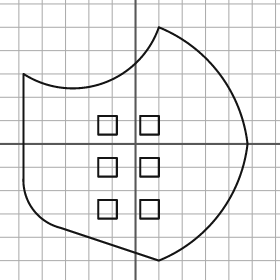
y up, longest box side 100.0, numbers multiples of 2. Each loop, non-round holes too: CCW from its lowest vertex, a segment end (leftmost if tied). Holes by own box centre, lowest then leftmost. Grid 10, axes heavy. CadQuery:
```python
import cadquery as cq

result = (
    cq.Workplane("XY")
    .moveTo(10.0, -50.0)
    .threePointArc((36.0, -30.0), (48.0, 0.0))
    .threePointArc((36.0, 30.0), (10.0, 50.0))
    .threePointArc((-14.0, 26.0), (-48.0, 30.0))
    .lineTo(-48.0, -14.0)
    .threePointArc((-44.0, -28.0), (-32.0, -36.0))
    .close()
    .moveTo(-16.0, -32.0)
    .lineTo(-8.0, -32.0)
    .lineTo(-8.0, -24.0)
    .lineTo(-16.0, -24.0)
    .close()
    .moveTo(2.0, -32.0)
    .lineTo(10.0, -32.0)
    .lineTo(10.0, -24.0)
    .lineTo(2.0, -24.0)
    .close()
    .moveTo(-16.0, -14.0)
    .lineTo(-8.0, -14.0)
    .lineTo(-8.0, -6.0)
    .lineTo(-16.0, -6.0)
    .close()
    .moveTo(2.0, -14.0)
    .lineTo(10.0, -14.0)
    .lineTo(10.0, -6.0)
    .lineTo(2.0, -6.0)
    .close()
    .moveTo(-16.0, 4.0)
    .lineTo(-8.0, 4.0)
    .lineTo(-8.0, 12.0)
    .lineTo(-16.0, 12.0)
    .close()
    .moveTo(2.0, 4.0)
    .lineTo(10.0, 4.0)
    .lineTo(10.0, 12.0)
    .lineTo(2.0, 12.0)
    .close()
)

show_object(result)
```